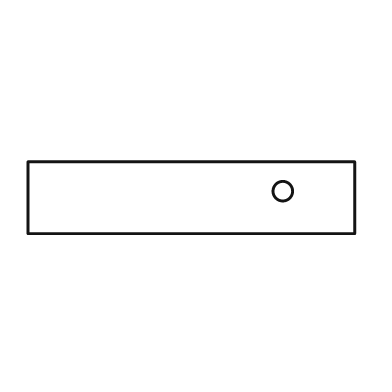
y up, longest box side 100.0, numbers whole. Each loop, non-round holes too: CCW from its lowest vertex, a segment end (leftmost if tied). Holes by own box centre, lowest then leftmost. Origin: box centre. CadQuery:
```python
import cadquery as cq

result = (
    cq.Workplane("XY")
    .moveTo(-50.0, -11.0)
    .lineTo(50.0, -11.0)
    .lineTo(50.0, 11.0)
    .lineTo(-50.0, 11.0)
    .close()
    .moveTo(28.0, 2.0)
    .circle(3.0)
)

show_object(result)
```